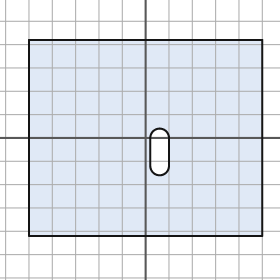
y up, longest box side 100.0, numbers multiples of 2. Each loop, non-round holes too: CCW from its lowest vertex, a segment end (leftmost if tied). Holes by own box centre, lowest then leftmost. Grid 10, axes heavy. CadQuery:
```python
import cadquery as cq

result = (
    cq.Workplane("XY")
    .moveTo(-50.0, -42.0)
    .lineTo(50.0, -42.0)
    .lineTo(50.0, 42.0)
    .lineTo(-50.0, 42.0)
    .close()
    .moveTo(2.0, -12.0)
    .threePointArc((6.0, -16.0), (10.0, -12.0))
    .lineTo(10.0, 0.0)
    .threePointArc((6.0, 4.0), (2.0, 0.0))
    .close()
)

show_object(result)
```